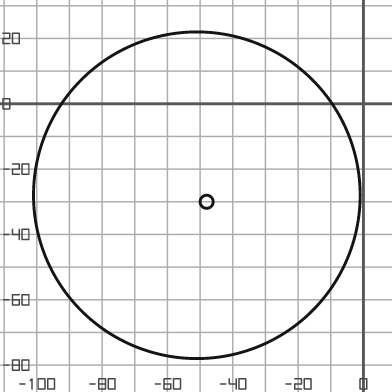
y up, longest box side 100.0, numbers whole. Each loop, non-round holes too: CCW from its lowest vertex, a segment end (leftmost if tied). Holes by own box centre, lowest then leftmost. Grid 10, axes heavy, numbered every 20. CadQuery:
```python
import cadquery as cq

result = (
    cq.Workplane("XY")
    .moveTo(-51.0, -28.0)
    .circle(50.0)
    .moveTo(-48.0, -30.0)
    .circle(2.0)
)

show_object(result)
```